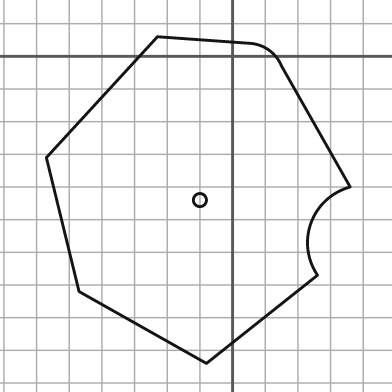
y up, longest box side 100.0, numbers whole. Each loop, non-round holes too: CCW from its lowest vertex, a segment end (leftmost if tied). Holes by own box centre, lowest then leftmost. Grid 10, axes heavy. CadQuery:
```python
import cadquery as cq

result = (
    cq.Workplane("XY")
    .moveTo(-8.0, -94.0)
    .lineTo(26.0, -67.0)
    .threePointArc((24.0, -51.0), (36.0, -40.0))
    .lineTo(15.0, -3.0)
    .threePointArc((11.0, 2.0), (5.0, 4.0))
    .lineTo(-23.0, 6.0)
    .lineTo(-57.0, -31.0)
    .lineTo(-47.0, -72.0)
    .close()
    .moveTo(-10.0, -44.0)
    .circle(2.0)
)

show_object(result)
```